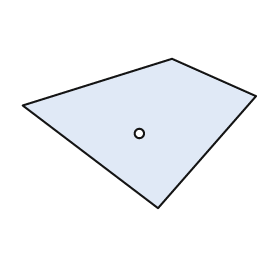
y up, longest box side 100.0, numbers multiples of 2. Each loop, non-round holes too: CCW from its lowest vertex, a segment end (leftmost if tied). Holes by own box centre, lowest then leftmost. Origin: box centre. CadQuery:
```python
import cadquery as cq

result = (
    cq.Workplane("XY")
    .moveTo(8.0, -32.0)
    .lineTo(50.0, 16.0)
    .lineTo(14.0, 32.0)
    .lineTo(-50.0, 12.0)
    .close()
    .moveTo(0.0, 0.0)
    .circle(2.0)
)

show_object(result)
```